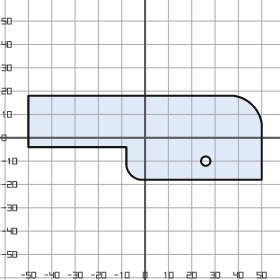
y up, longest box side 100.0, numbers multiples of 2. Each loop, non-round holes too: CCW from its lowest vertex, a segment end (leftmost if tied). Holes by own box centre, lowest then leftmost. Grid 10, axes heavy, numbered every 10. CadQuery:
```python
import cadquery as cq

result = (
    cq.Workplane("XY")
    .moveTo(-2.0, -18.0)
    .lineTo(50.0, -18.0)
    .lineTo(50.0, 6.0)
    .threePointArc((46.0, 14.0), (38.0, 18.0))
    .lineTo(-50.0, 18.0)
    .lineTo(-50.0, -4.0)
    .lineTo(-8.0, -4.0)
    .lineTo(-8.0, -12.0)
    .threePointArc((-6.0, -16.0), (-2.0, -18.0))
    .close()
    .moveTo(26.0, -10.0)
    .circle(2.0)
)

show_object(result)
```